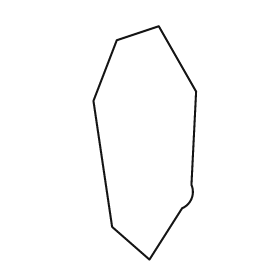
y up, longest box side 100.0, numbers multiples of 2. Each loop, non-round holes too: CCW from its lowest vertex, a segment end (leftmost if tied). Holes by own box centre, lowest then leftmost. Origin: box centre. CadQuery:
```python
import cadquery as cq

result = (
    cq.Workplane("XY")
    .moveTo(2.0, -50.0)
    .lineTo(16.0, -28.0)
    .threePointArc((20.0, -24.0), (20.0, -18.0))
    .lineTo(22.0, 22.0)
    .lineTo(6.0, 50.0)
    .lineTo(-12.0, 44.0)
    .lineTo(-22.0, 18.0)
    .lineTo(-14.0, -36.0)
    .close()
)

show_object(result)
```